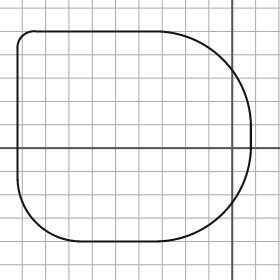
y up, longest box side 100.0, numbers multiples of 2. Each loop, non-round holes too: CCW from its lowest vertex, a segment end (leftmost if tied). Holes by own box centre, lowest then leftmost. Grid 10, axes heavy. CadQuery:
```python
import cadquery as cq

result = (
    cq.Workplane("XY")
    .moveTo(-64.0, -40.0)
    .lineTo(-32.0, -40.0)
    .threePointArc((-4.0, -28.0), (8.0, 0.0))
    .lineTo(8.0, 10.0)
    .threePointArc((-4.0, 38.0), (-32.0, 50.0))
    .lineTo(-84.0, 50.0)
    .threePointArc((-90.0, 48.0), (-92.0, 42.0))
    .lineTo(-92.0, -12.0)
    .threePointArc((-84.0, -32.0), (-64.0, -40.0))
    .close()
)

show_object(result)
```